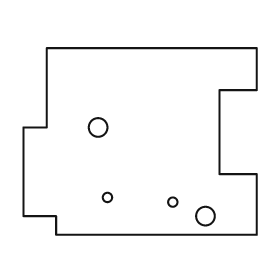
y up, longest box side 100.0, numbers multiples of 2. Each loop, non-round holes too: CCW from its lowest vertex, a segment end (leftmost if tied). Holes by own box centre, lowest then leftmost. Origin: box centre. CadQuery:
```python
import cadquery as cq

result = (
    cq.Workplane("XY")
    .moveTo(-36.0, -40.0)
    .lineTo(50.0, -40.0)
    .lineTo(50.0, -14.0)
    .lineTo(34.0, -14.0)
    .lineTo(34.0, 22.0)
    .lineTo(50.0, 22.0)
    .lineTo(50.0, 40.0)
    .lineTo(-40.0, 40.0)
    .lineTo(-40.0, 6.0)
    .lineTo(-50.0, 6.0)
    .lineTo(-50.0, -32.0)
    .lineTo(-36.0, -32.0)
    .close()
    .moveTo(28.0, -32.0)
    .circle(4.0)
    .moveTo(14.0, -26.0)
    .circle(2.0)
    .moveTo(-14.0, -24.0)
    .circle(2.0)
    .moveTo(-18.0, 6.0)
    .circle(4.0)
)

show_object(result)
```